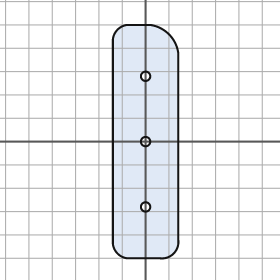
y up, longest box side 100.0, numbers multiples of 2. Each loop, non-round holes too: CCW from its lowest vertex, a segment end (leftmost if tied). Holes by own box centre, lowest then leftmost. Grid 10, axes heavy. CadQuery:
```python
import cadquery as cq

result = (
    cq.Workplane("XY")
    .moveTo(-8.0, -50.0)
    .lineTo(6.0, -50.0)
    .threePointArc((12.0, -48.0), (14.0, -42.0))
    .lineTo(14.0, 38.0)
    .threePointArc((10.0, 46.0), (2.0, 50.0))
    .lineTo(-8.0, 50.0)
    .threePointArc((-12.0, 48.0), (-14.0, 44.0))
    .lineTo(-14.0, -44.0)
    .threePointArc((-12.0, -48.0), (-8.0, -50.0))
    .close()
    .moveTo(0.0, -28.0)
    .circle(2.0)
    .moveTo(0.0, 0.0)
    .circle(2.0)
    .moveTo(0.0, 28.0)
    .circle(2.0)
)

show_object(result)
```